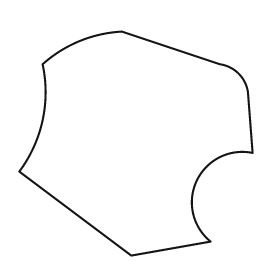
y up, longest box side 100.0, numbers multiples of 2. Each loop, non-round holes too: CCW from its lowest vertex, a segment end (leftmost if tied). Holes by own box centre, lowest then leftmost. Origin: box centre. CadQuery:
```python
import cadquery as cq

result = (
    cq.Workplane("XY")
    .moveTo(-2.0, -48.0)
    .lineTo(32.0, -42.0)
    .threePointArc((26.0, -16.0), (50.0, -4.0))
    .lineTo(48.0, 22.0)
    .threePointArc((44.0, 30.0), (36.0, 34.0))
    .lineTo(-6.0, 48.0)
    .threePointArc((-24.0, 44.0), (-40.0, 34.0))
    .threePointArc((-40.0, 10.0), (-50.0, -12.0))
    .close()
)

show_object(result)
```